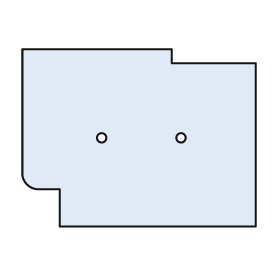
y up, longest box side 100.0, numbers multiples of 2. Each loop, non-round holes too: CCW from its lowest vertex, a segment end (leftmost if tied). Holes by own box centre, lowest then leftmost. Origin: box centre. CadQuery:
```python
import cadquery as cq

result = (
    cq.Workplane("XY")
    .moveTo(-34.0, -38.0)
    .lineTo(50.0, -38.0)
    .lineTo(50.0, 32.0)
    .lineTo(14.0, 32.0)
    .lineTo(14.0, 38.0)
    .lineTo(-50.0, 38.0)
    .lineTo(-50.0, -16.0)
    .threePointArc((-48.0, -20.0), (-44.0, -22.0))
    .lineTo(-34.0, -22.0)
    .close()
    .moveTo(-16.0, 0.0)
    .circle(2.0)
    .moveTo(18.0, 0.0)
    .circle(2.0)
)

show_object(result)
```